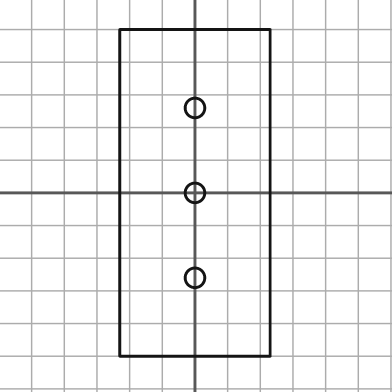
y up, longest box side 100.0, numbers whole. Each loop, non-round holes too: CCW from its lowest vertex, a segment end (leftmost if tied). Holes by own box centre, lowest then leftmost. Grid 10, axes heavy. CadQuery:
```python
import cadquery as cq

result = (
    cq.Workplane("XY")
    .moveTo(-23.0, -50.0)
    .lineTo(23.0, -50.0)
    .lineTo(23.0, 50.0)
    .lineTo(-23.0, 50.0)
    .close()
    .moveTo(0.0, -26.0)
    .circle(3.0)
    .moveTo(0.0, 0.0)
    .circle(3.0)
    .moveTo(0.0, 26.0)
    .circle(3.0)
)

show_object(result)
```